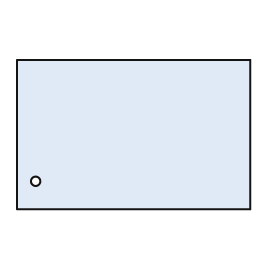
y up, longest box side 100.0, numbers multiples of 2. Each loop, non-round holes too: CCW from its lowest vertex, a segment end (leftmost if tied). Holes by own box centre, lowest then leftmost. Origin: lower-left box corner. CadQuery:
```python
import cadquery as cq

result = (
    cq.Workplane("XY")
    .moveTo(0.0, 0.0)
    .lineTo(100.0, 0.0)
    .lineTo(100.0, 64.0)
    .lineTo(0.0, 64.0)
    .close()
    .moveTo(8.0, 12.0)
    .circle(2.0)
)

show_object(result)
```